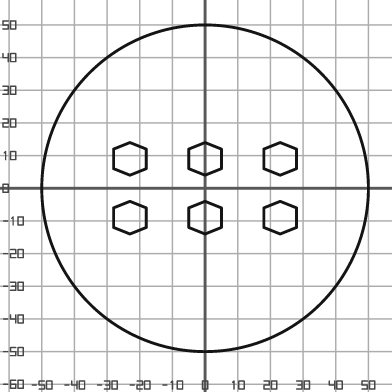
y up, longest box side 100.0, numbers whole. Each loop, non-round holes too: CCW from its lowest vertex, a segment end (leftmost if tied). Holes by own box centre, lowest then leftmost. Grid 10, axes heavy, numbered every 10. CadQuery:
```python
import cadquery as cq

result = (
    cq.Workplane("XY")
    .moveTo(0.0, 0.0)
    .circle(50.0)
    .moveTo(-23.0, -14.0)
    .lineTo(-18.0, -12.0)
    .lineTo(-18.0, -6.0)
    .lineTo(-23.0, -4.0)
    .lineTo(-28.0, -6.0)
    .lineTo(-28.0, -12.0)
    .close()
    .moveTo(0.0, -14.0)
    .lineTo(5.0, -12.0)
    .lineTo(5.0, -6.0)
    .lineTo(0.0, -4.0)
    .lineTo(-5.0, -6.0)
    .lineTo(-5.0, -12.0)
    .close()
    .moveTo(23.0, -14.0)
    .lineTo(28.0, -12.0)
    .lineTo(28.0, -6.0)
    .lineTo(23.0, -4.0)
    .lineTo(18.0, -6.0)
    .lineTo(18.0, -12.0)
    .close()
    .moveTo(-23.0, 4.0)
    .lineTo(-18.0, 6.0)
    .lineTo(-18.0, 12.0)
    .lineTo(-23.0, 14.0)
    .lineTo(-28.0, 12.0)
    .lineTo(-28.0, 6.0)
    .close()
    .moveTo(0.0, 4.0)
    .lineTo(5.0, 6.0)
    .lineTo(5.0, 12.0)
    .lineTo(0.0, 14.0)
    .lineTo(-5.0, 12.0)
    .lineTo(-5.0, 6.0)
    .close()
    .moveTo(23.0, 4.0)
    .lineTo(28.0, 6.0)
    .lineTo(28.0, 12.0)
    .lineTo(23.0, 14.0)
    .lineTo(18.0, 12.0)
    .lineTo(18.0, 6.0)
    .close()
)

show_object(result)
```